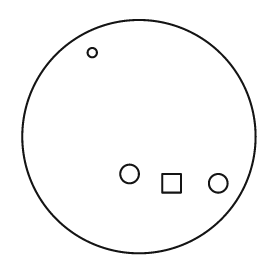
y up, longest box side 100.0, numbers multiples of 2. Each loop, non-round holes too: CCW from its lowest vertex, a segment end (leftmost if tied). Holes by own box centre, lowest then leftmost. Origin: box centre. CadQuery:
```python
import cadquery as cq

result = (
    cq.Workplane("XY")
    .moveTo(0.0, 0.0)
    .circle(50.0)
    .moveTo(10.0, -24.0)
    .lineTo(18.0, -24.0)
    .lineTo(18.0, -16.0)
    .lineTo(10.0, -16.0)
    .close()
    .moveTo(34.0, -20.0)
    .circle(4.0)
    .moveTo(-4.0, -16.0)
    .circle(4.0)
    .moveTo(-20.0, 36.0)
    .circle(2.0)
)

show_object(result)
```